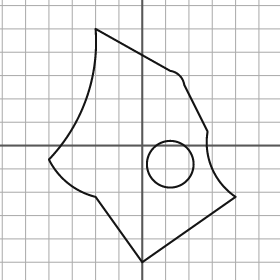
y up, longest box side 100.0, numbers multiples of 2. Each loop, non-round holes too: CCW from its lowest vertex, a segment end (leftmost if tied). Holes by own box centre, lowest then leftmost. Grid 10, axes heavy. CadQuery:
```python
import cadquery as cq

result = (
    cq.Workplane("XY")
    .moveTo(0.0, -50.0)
    .lineTo(40.0, -22.0)
    .threePointArc((30.0, -10.0), (28.0, 6.0))
    .lineTo(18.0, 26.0)
    .threePointArc((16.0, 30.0), (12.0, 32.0))
    .lineTo(-20.0, 50.0)
    .threePointArc((-24.0, 20.0), (-40.0, -6.0))
    .threePointArc((-32.0, -16.0), (-20.0, -22.0))
    .close()
    .moveTo(12.0, -8.0)
    .circle(10.0)
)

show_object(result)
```